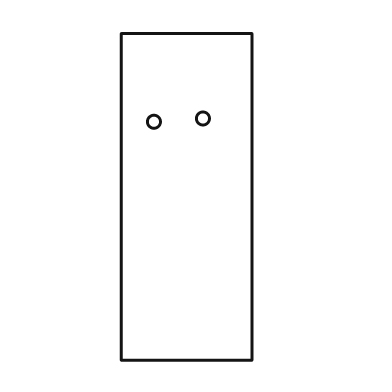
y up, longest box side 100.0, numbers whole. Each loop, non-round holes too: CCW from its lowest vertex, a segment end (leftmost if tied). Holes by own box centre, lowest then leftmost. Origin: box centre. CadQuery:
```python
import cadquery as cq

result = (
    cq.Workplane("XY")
    .moveTo(-20.0, -50.0)
    .lineTo(20.0, -50.0)
    .lineTo(20.0, 50.0)
    .lineTo(-20.0, 50.0)
    .close()
    .moveTo(-10.0, 23.0)
    .circle(2.0)
    .moveTo(5.0, 24.0)
    .circle(2.0)
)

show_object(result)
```